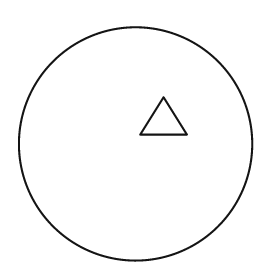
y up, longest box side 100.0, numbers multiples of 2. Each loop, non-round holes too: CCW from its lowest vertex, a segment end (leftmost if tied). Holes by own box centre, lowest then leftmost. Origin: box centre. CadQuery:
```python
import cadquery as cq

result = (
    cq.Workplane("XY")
    .moveTo(0.0, 0.0)
    .circle(50.0)
    .moveTo(2.0, 4.0)
    .lineTo(22.0, 4.0)
    .lineTo(12.0, 20.0)
    .close()
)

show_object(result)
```